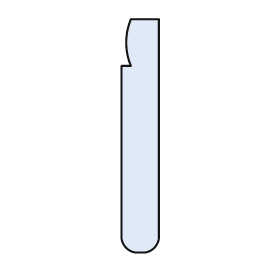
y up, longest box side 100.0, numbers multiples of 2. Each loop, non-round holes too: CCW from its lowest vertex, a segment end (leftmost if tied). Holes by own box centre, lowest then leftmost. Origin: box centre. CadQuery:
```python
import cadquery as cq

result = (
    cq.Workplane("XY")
    .moveTo(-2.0, -50.0)
    .lineTo(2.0, -50.0)
    .threePointArc((6.0, -48.0), (8.0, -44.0))
    .lineTo(8.0, 50.0)
    .lineTo(-4.0, 50.0)
    .threePointArc((-6.0, 40.0), (-4.0, 30.0))
    .lineTo(-8.0, 30.0)
    .lineTo(-8.0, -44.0)
    .threePointArc((-6.0, -48.0), (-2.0, -50.0))
    .close()
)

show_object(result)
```